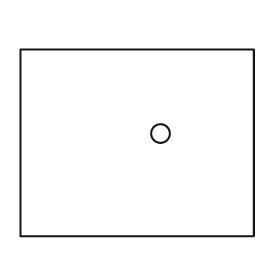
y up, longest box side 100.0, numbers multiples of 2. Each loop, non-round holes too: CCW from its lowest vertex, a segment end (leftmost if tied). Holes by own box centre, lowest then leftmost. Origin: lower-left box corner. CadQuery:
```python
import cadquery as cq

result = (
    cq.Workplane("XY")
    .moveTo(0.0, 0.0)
    .lineTo(100.0, 0.0)
    .lineTo(100.0, 80.0)
    .lineTo(0.0, 80.0)
    .close()
    .moveTo(60.0, 44.0)
    .circle(4.0)
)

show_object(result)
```